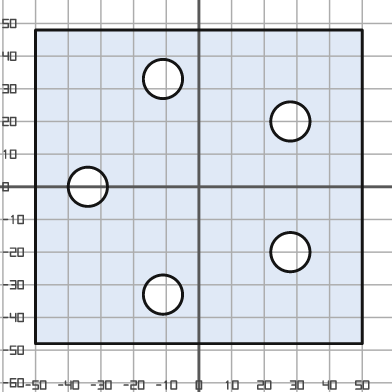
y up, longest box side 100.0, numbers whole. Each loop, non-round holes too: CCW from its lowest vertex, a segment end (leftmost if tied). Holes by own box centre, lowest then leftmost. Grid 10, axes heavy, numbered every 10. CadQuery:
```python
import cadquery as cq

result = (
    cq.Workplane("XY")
    .moveTo(-50.0, -48.0)
    .lineTo(50.0, -48.0)
    .lineTo(50.0, 48.0)
    .lineTo(-50.0, 48.0)
    .close()
    .moveTo(-11.0, -33.0)
    .circle(6.0)
    .moveTo(28.0, -20.0)
    .circle(6.0)
    .moveTo(-34.0, 0.0)
    .circle(6.0)
    .moveTo(28.0, 20.0)
    .circle(6.0)
    .moveTo(-11.0, 33.0)
    .circle(6.0)
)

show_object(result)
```